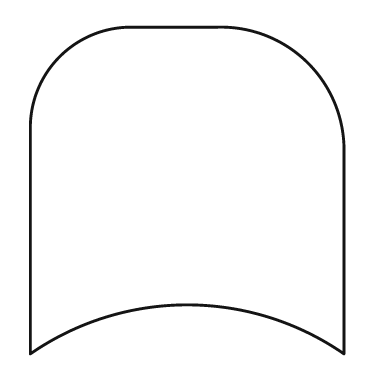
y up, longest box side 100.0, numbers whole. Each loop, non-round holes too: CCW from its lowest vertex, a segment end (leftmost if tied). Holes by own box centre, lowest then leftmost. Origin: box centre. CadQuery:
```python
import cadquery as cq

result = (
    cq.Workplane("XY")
    .moveTo(-48.0, -50.0)
    .threePointArc((0.0, -35.0), (48.0, -50.0))
    .lineTo(48.0, 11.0)
    .threePointArc((37.0, 39.0), (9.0, 50.0))
    .lineTo(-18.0, 50.0)
    .threePointArc((-39.0, 41.0), (-48.0, 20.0))
    .close()
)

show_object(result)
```